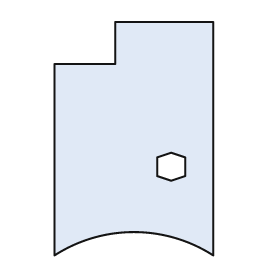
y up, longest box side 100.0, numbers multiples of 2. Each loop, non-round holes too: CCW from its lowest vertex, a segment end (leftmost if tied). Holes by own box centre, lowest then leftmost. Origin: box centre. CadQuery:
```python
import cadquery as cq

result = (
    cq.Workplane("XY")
    .moveTo(-34.0, -50.0)
    .threePointArc((0.0, -40.0), (34.0, -50.0))
    .lineTo(34.0, 50.0)
    .lineTo(-8.0, 50.0)
    .lineTo(-8.0, 32.0)
    .lineTo(-34.0, 32.0)
    .close()
    .moveTo(16.0, -18.0)
    .lineTo(22.0, -16.0)
    .lineTo(22.0, -8.0)
    .lineTo(16.0, -6.0)
    .lineTo(10.0, -8.0)
    .lineTo(10.0, -16.0)
    .close()
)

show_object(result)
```